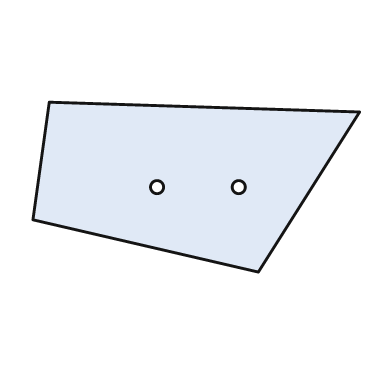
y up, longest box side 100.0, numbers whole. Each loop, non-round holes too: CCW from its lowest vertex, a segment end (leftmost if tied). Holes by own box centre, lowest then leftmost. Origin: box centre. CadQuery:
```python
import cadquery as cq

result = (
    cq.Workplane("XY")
    .moveTo(19.0, -26.0)
    .lineTo(50.0, 23.0)
    .lineTo(-45.0, 26.0)
    .lineTo(-50.0, -10.0)
    .close()
    .moveTo(-12.0, 0.0)
    .circle(2.0)
    .moveTo(13.0, 0.0)
    .circle(2.0)
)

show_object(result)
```